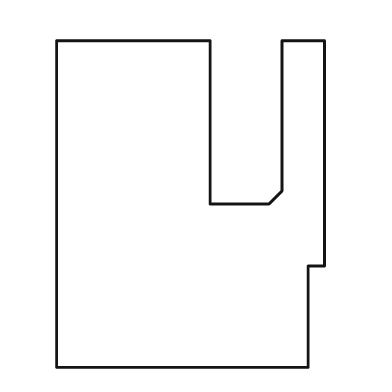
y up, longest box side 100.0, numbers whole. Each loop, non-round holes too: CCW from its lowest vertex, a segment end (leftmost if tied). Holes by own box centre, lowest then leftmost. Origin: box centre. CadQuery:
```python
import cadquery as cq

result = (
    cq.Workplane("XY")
    .moveTo(-41.0, -50.0)
    .lineTo(36.0, -50.0)
    .lineTo(36.0, -19.0)
    .lineTo(41.0, -19.0)
    .lineTo(41.0, 50.0)
    .lineTo(28.0, 50.0)
    .lineTo(28.0, 4.0)
    .lineTo(24.0, 0.0)
    .lineTo(6.0, 0.0)
    .lineTo(6.0, 50.0)
    .lineTo(-41.0, 50.0)
    .close()
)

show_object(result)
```